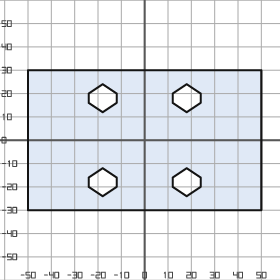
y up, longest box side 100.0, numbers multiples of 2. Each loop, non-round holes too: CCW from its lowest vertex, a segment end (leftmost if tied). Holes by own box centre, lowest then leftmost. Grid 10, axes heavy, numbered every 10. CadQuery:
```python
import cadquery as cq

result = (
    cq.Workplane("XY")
    .moveTo(-50.0, -30.0)
    .lineTo(50.0, -30.0)
    .lineTo(50.0, 30.0)
    .lineTo(-50.0, 30.0)
    .close()
    .moveTo(-18.0, -24.0)
    .lineTo(-12.0, -20.0)
    .lineTo(-12.0, -16.0)
    .lineTo(-18.0, -12.0)
    .lineTo(-24.0, -16.0)
    .lineTo(-24.0, -20.0)
    .close()
    .moveTo(18.0, -24.0)
    .lineTo(24.0, -20.0)
    .lineTo(24.0, -16.0)
    .lineTo(18.0, -12.0)
    .lineTo(12.0, -16.0)
    .lineTo(12.0, -20.0)
    .close()
    .moveTo(-18.0, 12.0)
    .lineTo(-12.0, 16.0)
    .lineTo(-12.0, 20.0)
    .lineTo(-18.0, 24.0)
    .lineTo(-24.0, 20.0)
    .lineTo(-24.0, 16.0)
    .close()
    .moveTo(18.0, 12.0)
    .lineTo(24.0, 16.0)
    .lineTo(24.0, 20.0)
    .lineTo(18.0, 24.0)
    .lineTo(12.0, 20.0)
    .lineTo(12.0, 16.0)
    .close()
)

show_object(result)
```